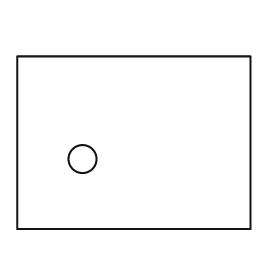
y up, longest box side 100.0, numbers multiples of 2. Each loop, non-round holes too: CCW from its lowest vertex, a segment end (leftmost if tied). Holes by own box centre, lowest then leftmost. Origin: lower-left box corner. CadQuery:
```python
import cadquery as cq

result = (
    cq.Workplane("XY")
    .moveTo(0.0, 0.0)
    .lineTo(100.0, 0.0)
    .lineTo(100.0, 74.0)
    .lineTo(0.0, 74.0)
    .close()
    .moveTo(28.0, 30.0)
    .circle(6.0)
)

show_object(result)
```